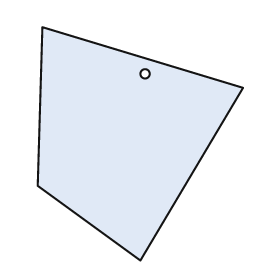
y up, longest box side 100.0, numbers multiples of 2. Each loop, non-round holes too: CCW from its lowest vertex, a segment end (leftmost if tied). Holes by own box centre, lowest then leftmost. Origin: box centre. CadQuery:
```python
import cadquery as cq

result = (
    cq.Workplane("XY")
    .moveTo(0.0, -50.0)
    .lineTo(44.0, 24.0)
    .lineTo(-42.0, 50.0)
    .lineTo(-44.0, -18.0)
    .close()
    .moveTo(2.0, 30.0)
    .circle(2.0)
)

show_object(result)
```